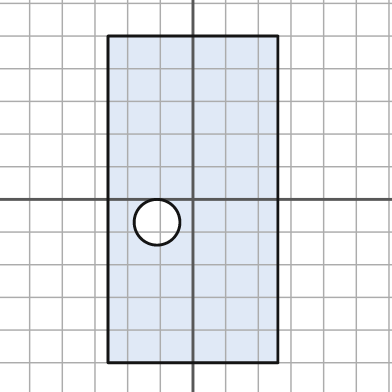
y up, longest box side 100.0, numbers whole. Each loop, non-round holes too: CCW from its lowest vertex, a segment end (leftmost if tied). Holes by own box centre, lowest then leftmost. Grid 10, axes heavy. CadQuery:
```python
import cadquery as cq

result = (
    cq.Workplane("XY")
    .moveTo(-26.0, -50.0)
    .lineTo(26.0, -50.0)
    .lineTo(26.0, 50.0)
    .lineTo(-26.0, 50.0)
    .close()
    .moveTo(-11.0, -7.0)
    .circle(7.0)
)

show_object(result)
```